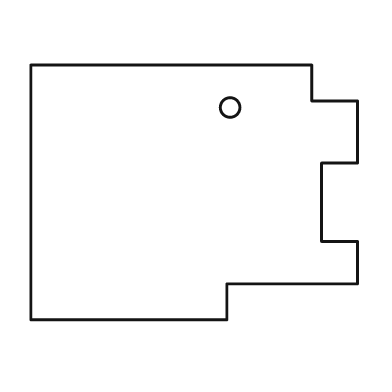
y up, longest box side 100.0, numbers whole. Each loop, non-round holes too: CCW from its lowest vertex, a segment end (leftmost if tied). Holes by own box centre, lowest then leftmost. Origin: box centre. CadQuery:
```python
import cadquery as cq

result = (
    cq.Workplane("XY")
    .moveTo(-50.0, -39.0)
    .lineTo(10.0, -39.0)
    .lineTo(10.0, -28.0)
    .lineTo(50.0, -28.0)
    .lineTo(50.0, -15.0)
    .lineTo(39.0, -15.0)
    .lineTo(39.0, 9.0)
    .lineTo(50.0, 9.0)
    .lineTo(50.0, 28.0)
    .lineTo(36.0, 28.0)
    .lineTo(36.0, 39.0)
    .lineTo(-50.0, 39.0)
    .close()
    .moveTo(11.0, 26.0)
    .circle(3.0)
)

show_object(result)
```